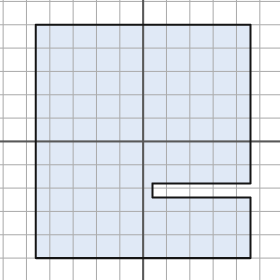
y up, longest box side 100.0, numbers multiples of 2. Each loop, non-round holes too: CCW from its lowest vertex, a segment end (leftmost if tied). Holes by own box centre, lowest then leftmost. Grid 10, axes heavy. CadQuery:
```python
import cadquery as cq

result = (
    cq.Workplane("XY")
    .moveTo(-46.0, -50.0)
    .lineTo(46.0, -50.0)
    .lineTo(46.0, -24.0)
    .lineTo(4.0, -24.0)
    .lineTo(4.0, -18.0)
    .lineTo(46.0, -18.0)
    .lineTo(46.0, 50.0)
    .lineTo(-46.0, 50.0)
    .close()
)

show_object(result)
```